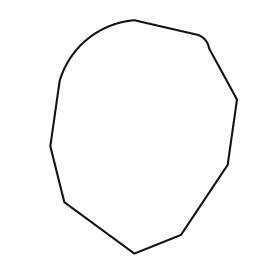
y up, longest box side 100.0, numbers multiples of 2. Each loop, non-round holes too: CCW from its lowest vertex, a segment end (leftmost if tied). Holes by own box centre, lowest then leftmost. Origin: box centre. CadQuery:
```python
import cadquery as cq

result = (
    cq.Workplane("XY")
    .moveTo(-4.0, -50.0)
    .lineTo(16.0, -42.0)
    .lineTo(36.0, -12.0)
    .lineTo(40.0, 16.0)
    .lineTo(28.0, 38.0)
    .threePointArc((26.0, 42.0), (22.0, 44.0))
    .lineTo(-4.0, 50.0)
    .threePointArc((-24.0, 42.0), (-36.0, 24.0))
    .lineTo(-40.0, -4.0)
    .lineTo(-34.0, -28.0)
    .close()
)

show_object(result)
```